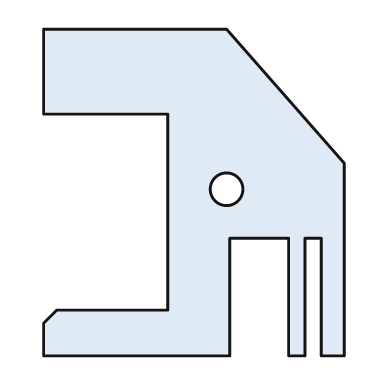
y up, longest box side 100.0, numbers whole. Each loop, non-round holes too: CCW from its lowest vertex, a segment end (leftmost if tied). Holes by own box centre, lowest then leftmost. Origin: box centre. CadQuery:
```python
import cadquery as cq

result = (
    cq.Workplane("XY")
    .moveTo(-46.0, -50.0)
    .lineTo(11.0, -50.0)
    .lineTo(11.0, -14.0)
    .lineTo(29.0, -14.0)
    .lineTo(29.0, -50.0)
    .lineTo(34.0, -50.0)
    .lineTo(34.0, -14.0)
    .lineTo(39.0, -14.0)
    .lineTo(39.0, -50.0)
    .lineTo(46.0, -50.0)
    .lineTo(46.0, 9.0)
    .lineTo(10.0, 50.0)
    .lineTo(-46.0, 50.0)
    .lineTo(-46.0, 24.0)
    .lineTo(-8.0, 24.0)
    .lineTo(-8.0, -36.0)
    .lineTo(-42.0, -36.0)
    .lineTo(-46.0, -40.0)
    .close()
    .moveTo(10.0, 1.0)
    .circle(5.0)
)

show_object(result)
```